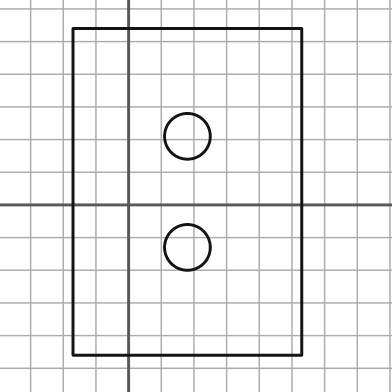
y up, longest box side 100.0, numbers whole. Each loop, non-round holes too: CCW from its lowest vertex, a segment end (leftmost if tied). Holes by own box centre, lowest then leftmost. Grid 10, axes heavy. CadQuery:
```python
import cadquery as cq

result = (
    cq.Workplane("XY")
    .moveTo(-17.0, -46.0)
    .lineTo(53.0, -46.0)
    .lineTo(53.0, 54.0)
    .lineTo(-17.0, 54.0)
    .close()
    .moveTo(18.0, -13.0)
    .circle(7.0)
    .moveTo(18.0, 21.0)
    .circle(7.0)
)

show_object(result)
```